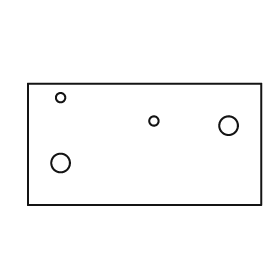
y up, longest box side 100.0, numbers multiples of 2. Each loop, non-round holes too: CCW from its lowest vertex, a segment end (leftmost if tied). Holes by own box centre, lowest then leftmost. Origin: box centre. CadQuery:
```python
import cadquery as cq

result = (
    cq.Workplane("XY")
    .moveTo(-50.0, -26.0)
    .lineTo(50.0, -26.0)
    .lineTo(50.0, 26.0)
    .lineTo(-50.0, 26.0)
    .close()
    .moveTo(-36.0, -8.0)
    .circle(4.0)
    .moveTo(36.0, 8.0)
    .circle(4.0)
    .moveTo(4.0, 10.0)
    .circle(2.0)
    .moveTo(-36.0, 20.0)
    .circle(2.0)
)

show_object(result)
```